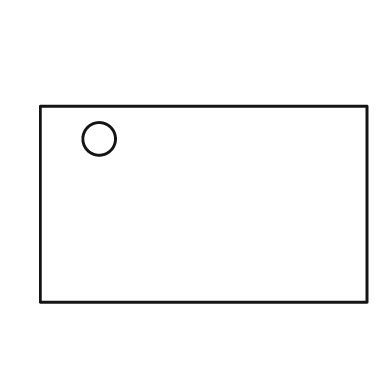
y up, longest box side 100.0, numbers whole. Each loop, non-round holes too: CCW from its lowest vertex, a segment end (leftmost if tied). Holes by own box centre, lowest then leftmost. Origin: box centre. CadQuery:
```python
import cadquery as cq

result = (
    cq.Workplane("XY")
    .moveTo(-50.0, -30.0)
    .lineTo(50.0, -30.0)
    .lineTo(50.0, 30.0)
    .lineTo(-50.0, 30.0)
    .close()
    .moveTo(-32.0, 20.0)
    .circle(5.0)
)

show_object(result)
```